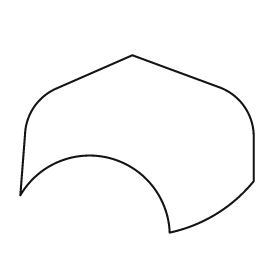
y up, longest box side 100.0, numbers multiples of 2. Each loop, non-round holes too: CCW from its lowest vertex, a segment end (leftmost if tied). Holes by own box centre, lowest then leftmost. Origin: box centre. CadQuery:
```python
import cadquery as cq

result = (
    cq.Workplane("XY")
    .moveTo(14.0, -38.0)
    .threePointArc((34.0, -30.0), (50.0, -16.0))
    .lineTo(50.0, 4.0)
    .threePointArc((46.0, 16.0), (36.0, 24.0))
    .lineTo(-2.0, 38.0)
    .lineTo(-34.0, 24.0)
    .threePointArc((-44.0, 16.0), (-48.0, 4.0))
    .lineTo(-50.0, -22.0)
    .threePointArc((-12.0, -6.0), (14.0, -38.0))
    .close()
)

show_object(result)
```